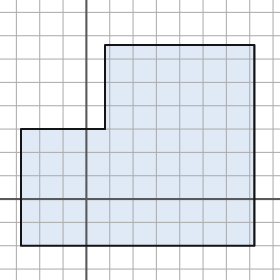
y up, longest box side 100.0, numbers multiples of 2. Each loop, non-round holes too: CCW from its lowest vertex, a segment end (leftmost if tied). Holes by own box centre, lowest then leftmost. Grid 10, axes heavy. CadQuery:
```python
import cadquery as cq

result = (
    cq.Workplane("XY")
    .moveTo(-28.0, -20.0)
    .lineTo(72.0, -20.0)
    .lineTo(72.0, 66.0)
    .lineTo(8.0, 66.0)
    .lineTo(8.0, 30.0)
    .lineTo(-28.0, 30.0)
    .close()
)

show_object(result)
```